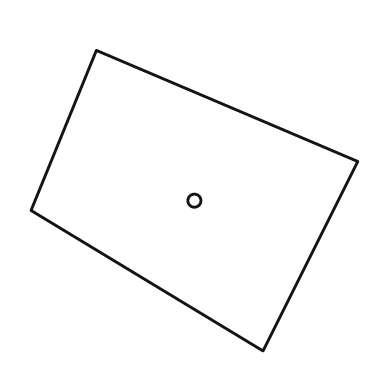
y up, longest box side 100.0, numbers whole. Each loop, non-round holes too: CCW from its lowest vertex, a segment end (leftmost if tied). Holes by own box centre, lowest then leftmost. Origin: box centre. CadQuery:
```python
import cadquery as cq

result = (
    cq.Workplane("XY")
    .moveTo(21.0, -46.0)
    .lineTo(50.0, 12.0)
    .lineTo(-30.0, 46.0)
    .lineTo(-50.0, -3.0)
    .close()
    .moveTo(0.0, 0.0)
    .circle(2.0)
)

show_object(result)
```